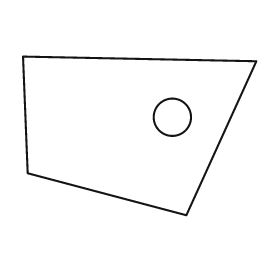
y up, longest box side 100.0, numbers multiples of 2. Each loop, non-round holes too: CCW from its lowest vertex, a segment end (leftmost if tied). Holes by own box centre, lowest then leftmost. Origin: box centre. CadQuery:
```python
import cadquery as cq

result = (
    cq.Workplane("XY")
    .moveTo(20.0, -34.0)
    .lineTo(50.0, 32.0)
    .lineTo(-50.0, 34.0)
    .lineTo(-48.0, -16.0)
    .close()
    .moveTo(14.0, 8.0)
    .circle(8.0)
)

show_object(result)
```